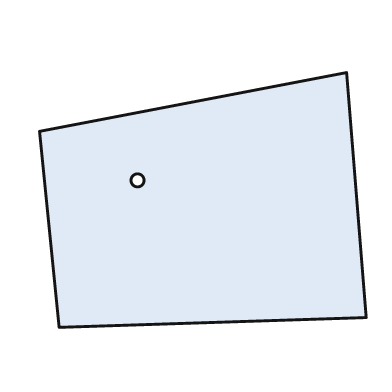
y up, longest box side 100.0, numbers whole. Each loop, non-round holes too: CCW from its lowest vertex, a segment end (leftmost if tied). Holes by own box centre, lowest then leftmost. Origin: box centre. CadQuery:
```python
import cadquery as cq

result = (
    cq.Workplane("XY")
    .moveTo(-44.0, -39.0)
    .lineTo(50.0, -36.0)
    .lineTo(44.0, 39.0)
    .lineTo(-50.0, 21.0)
    .close()
    .moveTo(-20.0, 6.0)
    .circle(2.0)
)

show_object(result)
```